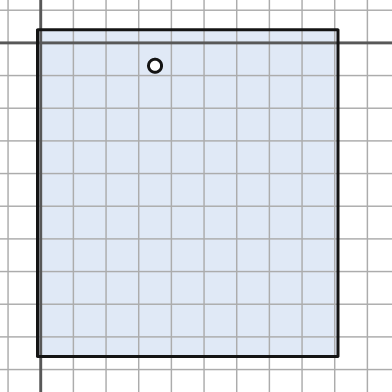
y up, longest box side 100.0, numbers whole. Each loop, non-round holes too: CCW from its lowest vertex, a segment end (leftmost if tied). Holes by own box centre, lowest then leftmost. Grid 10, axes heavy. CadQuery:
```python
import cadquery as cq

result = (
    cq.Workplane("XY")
    .moveTo(-1.0, -96.0)
    .lineTo(91.0, -96.0)
    .lineTo(91.0, 4.0)
    .lineTo(-1.0, 4.0)
    .close()
    .moveTo(35.0, -7.0)
    .circle(2.0)
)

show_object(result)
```